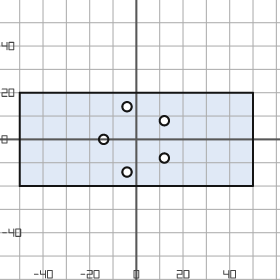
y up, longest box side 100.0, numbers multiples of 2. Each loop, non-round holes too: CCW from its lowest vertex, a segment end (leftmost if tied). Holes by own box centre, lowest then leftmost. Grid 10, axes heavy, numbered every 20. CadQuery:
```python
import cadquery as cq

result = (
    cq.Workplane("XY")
    .moveTo(-50.0, -20.0)
    .lineTo(50.0, -20.0)
    .lineTo(50.0, 20.0)
    .lineTo(-50.0, 20.0)
    .close()
    .moveTo(-4.0, -14.0)
    .circle(2.0)
    .moveTo(12.0, -8.0)
    .circle(2.0)
    .moveTo(-14.0, 0.0)
    .circle(2.0)
    .moveTo(12.0, 8.0)
    .circle(2.0)
    .moveTo(-4.0, 14.0)
    .circle(2.0)
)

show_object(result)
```